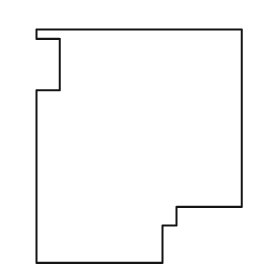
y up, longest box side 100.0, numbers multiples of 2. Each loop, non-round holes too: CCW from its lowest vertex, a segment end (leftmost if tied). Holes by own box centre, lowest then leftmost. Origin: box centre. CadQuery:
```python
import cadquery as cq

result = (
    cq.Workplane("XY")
    .moveTo(-44.0, -50.0)
    .lineTo(10.0, -50.0)
    .lineTo(10.0, -34.0)
    .lineTo(16.0, -34.0)
    .lineTo(16.0, -26.0)
    .lineTo(44.0, -26.0)
    .lineTo(44.0, 50.0)
    .lineTo(-44.0, 50.0)
    .lineTo(-44.0, 46.0)
    .lineTo(-34.0, 46.0)
    .lineTo(-34.0, 24.0)
    .lineTo(-44.0, 24.0)
    .close()
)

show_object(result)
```